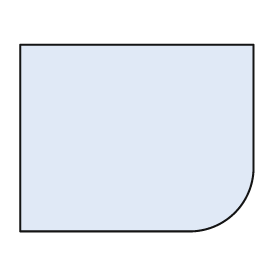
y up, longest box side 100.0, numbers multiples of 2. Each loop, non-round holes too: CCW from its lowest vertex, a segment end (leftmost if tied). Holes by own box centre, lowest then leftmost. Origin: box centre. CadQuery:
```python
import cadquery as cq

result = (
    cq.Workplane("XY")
    .moveTo(-50.0, -40.0)
    .lineTo(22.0, -40.0)
    .threePointArc((42.0, -32.0), (50.0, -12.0))
    .lineTo(50.0, 40.0)
    .lineTo(-50.0, 40.0)
    .close()
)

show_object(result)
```